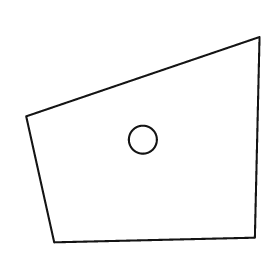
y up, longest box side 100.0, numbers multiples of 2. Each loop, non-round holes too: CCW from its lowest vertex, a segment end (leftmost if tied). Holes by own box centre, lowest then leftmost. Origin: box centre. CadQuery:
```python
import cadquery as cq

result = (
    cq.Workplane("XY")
    .moveTo(-38.0, -44.0)
    .lineTo(48.0, -42.0)
    .lineTo(50.0, 44.0)
    .lineTo(-50.0, 10.0)
    .close()
    .moveTo(0.0, 0.0)
    .circle(6.0)
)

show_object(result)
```